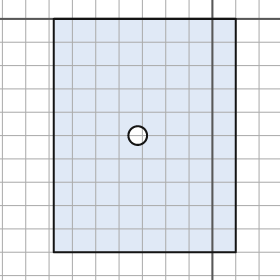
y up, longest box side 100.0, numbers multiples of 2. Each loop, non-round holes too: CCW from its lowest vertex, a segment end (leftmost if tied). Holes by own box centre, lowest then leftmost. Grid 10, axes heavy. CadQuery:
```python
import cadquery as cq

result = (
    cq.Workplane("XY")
    .moveTo(-68.0, -100.0)
    .lineTo(10.0, -100.0)
    .lineTo(10.0, 0.0)
    .lineTo(-68.0, 0.0)
    .close()
    .moveTo(-32.0, -50.0)
    .circle(4.0)
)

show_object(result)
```